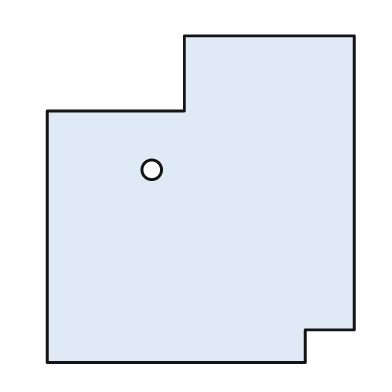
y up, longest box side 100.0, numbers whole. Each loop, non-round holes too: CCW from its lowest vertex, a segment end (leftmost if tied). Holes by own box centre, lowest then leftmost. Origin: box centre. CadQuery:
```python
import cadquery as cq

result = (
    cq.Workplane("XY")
    .moveTo(-47.0, -50.0)
    .lineTo(32.0, -50.0)
    .lineTo(32.0, -40.0)
    .lineTo(47.0, -40.0)
    .lineTo(47.0, 50.0)
    .lineTo(-5.0, 50.0)
    .lineTo(-5.0, 27.0)
    .lineTo(-47.0, 27.0)
    .close()
    .moveTo(-15.0, 9.0)
    .circle(3.0)
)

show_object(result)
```